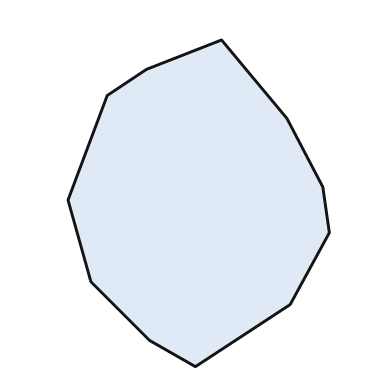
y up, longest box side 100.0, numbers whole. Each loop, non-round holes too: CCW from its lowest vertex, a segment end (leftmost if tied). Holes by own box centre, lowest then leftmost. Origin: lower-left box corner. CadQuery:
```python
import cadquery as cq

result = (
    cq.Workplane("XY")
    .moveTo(39.0, 0.0)
    .lineTo(68.0, 19.0)
    .lineTo(80.0, 41.0)
    .lineTo(78.0, 55.0)
    .lineTo(67.0, 76.0)
    .lineTo(47.0, 100.0)
    .lineTo(24.0, 91.0)
    .lineTo(12.0, 83.0)
    .lineTo(0.0, 51.0)
    .lineTo(7.0, 26.0)
    .lineTo(25.0, 8.0)
    .close()
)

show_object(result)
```